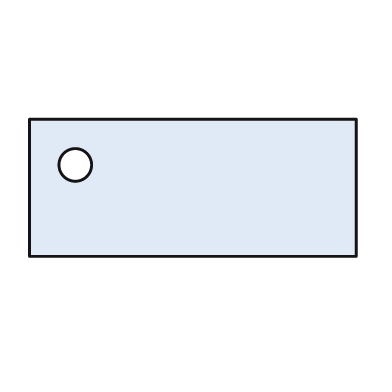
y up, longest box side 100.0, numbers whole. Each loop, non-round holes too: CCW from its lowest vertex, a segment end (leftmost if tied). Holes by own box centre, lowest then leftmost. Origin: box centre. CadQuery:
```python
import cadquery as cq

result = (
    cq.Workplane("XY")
    .moveTo(-50.0, -21.0)
    .lineTo(50.0, -21.0)
    .lineTo(50.0, 21.0)
    .lineTo(-50.0, 21.0)
    .close()
    .moveTo(-36.0, 7.0)
    .circle(5.0)
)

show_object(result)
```